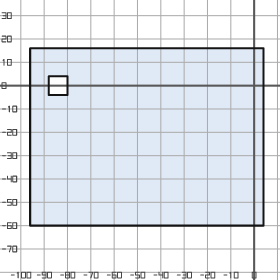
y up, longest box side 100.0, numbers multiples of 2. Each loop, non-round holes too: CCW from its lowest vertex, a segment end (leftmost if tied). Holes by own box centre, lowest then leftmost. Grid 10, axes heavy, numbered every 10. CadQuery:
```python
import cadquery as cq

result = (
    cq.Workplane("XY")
    .moveTo(-96.0, -60.0)
    .lineTo(4.0, -60.0)
    .lineTo(4.0, 16.0)
    .lineTo(-96.0, 16.0)
    .close()
    .moveTo(-88.0, -4.0)
    .lineTo(-80.0, -4.0)
    .lineTo(-80.0, 4.0)
    .lineTo(-88.0, 4.0)
    .close()
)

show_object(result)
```